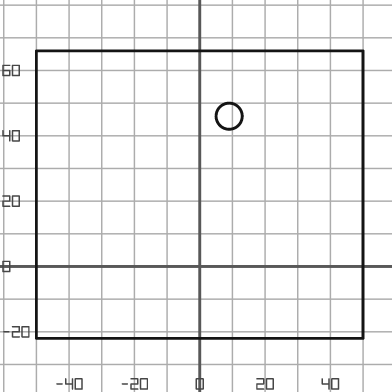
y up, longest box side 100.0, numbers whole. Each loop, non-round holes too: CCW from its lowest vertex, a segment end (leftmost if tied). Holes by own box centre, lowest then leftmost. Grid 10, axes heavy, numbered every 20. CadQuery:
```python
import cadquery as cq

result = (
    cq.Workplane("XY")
    .moveTo(-50.0, -22.0)
    .lineTo(50.0, -22.0)
    .lineTo(50.0, 66.0)
    .lineTo(-50.0, 66.0)
    .close()
    .moveTo(9.0, 46.0)
    .circle(4.0)
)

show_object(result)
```